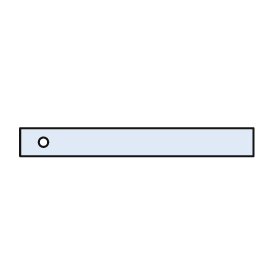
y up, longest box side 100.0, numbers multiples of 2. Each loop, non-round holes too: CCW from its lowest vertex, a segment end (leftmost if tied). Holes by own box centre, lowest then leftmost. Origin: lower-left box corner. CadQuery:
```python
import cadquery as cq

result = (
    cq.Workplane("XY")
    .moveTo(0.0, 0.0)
    .lineTo(100.0, 0.0)
    .lineTo(100.0, 12.0)
    .lineTo(0.0, 12.0)
    .close()
    .moveTo(10.0, 6.0)
    .circle(2.0)
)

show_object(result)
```